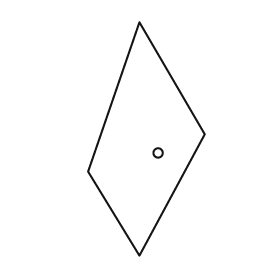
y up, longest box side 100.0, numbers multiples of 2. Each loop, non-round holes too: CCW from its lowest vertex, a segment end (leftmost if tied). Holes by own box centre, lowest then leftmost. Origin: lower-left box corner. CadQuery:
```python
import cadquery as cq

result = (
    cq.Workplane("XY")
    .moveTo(22.0, 0.0)
    .lineTo(50.0, 52.0)
    .lineTo(22.0, 100.0)
    .lineTo(0.0, 36.0)
    .close()
    .moveTo(30.0, 44.0)
    .circle(2.0)
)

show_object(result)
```